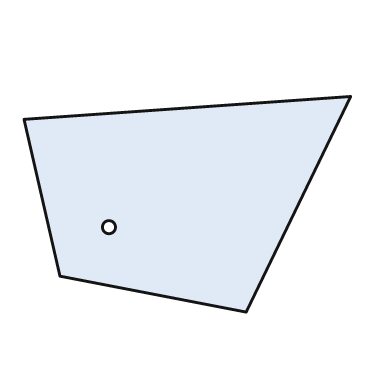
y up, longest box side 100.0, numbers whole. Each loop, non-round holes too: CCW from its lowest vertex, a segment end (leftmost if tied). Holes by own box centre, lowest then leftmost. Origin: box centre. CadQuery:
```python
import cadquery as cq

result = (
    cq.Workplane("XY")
    .moveTo(18.0, -33.0)
    .lineTo(50.0, 33.0)
    .lineTo(-50.0, 26.0)
    .lineTo(-39.0, -22.0)
    .close()
    .moveTo(-24.0, -7.0)
    .circle(2.0)
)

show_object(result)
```